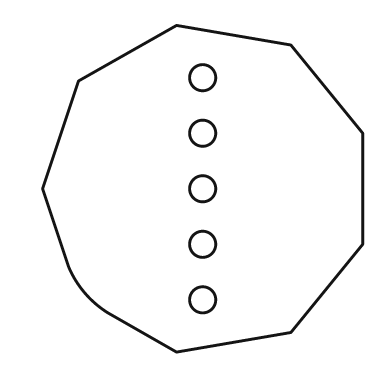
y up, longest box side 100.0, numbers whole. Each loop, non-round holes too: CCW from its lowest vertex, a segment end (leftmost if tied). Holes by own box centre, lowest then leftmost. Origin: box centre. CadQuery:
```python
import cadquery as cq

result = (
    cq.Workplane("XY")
    .moveTo(-8.0, -50.0)
    .lineTo(27.0, -44.0)
    .lineTo(49.0, -17.0)
    .lineTo(49.0, 17.0)
    .lineTo(27.0, 44.0)
    .lineTo(-8.0, 50.0)
    .lineTo(-38.0, 33.0)
    .lineTo(-49.0, 0.0)
    .lineTo(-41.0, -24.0)
    .threePointArc((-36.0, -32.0), (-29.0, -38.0))
    .close()
    .moveTo(0.0, -34.0)
    .circle(4.0)
    .moveTo(0.0, -17.0)
    .circle(4.0)
    .moveTo(0.0, 0.0)
    .circle(4.0)
    .moveTo(0.0, 17.0)
    .circle(4.0)
    .moveTo(0.0, 34.0)
    .circle(4.0)
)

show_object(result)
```